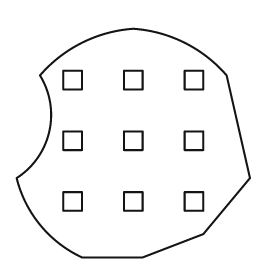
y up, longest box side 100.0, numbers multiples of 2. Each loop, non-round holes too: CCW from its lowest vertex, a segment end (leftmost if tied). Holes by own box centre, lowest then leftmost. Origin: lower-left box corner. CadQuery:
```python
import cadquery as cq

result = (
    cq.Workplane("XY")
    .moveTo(28.0, 0.0)
    .lineTo(54.0, 0.0)
    .lineTo(80.0, 10.0)
    .lineTo(100.0, 34.0)
    .lineTo(90.0, 78.0)
    .threePointArc((72.0, 92.0), (50.0, 98.0))
    .threePointArc((28.0, 92.0), (10.0, 78.0))
    .threePointArc((14.0, 54.0), (0.0, 34.0))
    .threePointArc((10.0, 14.0), (28.0, 0.0))
    .close()
    .moveTo(20.0, 20.0)
    .lineTo(28.0, 20.0)
    .lineTo(28.0, 28.0)
    .lineTo(20.0, 28.0)
    .close()
    .moveTo(46.0, 20.0)
    .lineTo(54.0, 20.0)
    .lineTo(54.0, 28.0)
    .lineTo(46.0, 28.0)
    .close()
    .moveTo(72.0, 20.0)
    .lineTo(80.0, 20.0)
    .lineTo(80.0, 28.0)
    .lineTo(72.0, 28.0)
    .close()
    .moveTo(20.0, 46.0)
    .lineTo(28.0, 46.0)
    .lineTo(28.0, 54.0)
    .lineTo(20.0, 54.0)
    .close()
    .moveTo(46.0, 46.0)
    .lineTo(54.0, 46.0)
    .lineTo(54.0, 54.0)
    .lineTo(46.0, 54.0)
    .close()
    .moveTo(72.0, 46.0)
    .lineTo(80.0, 46.0)
    .lineTo(80.0, 54.0)
    .lineTo(72.0, 54.0)
    .close()
    .moveTo(20.0, 72.0)
    .lineTo(28.0, 72.0)
    .lineTo(28.0, 80.0)
    .lineTo(20.0, 80.0)
    .close()
    .moveTo(46.0, 72.0)
    .lineTo(54.0, 72.0)
    .lineTo(54.0, 80.0)
    .lineTo(46.0, 80.0)
    .close()
    .moveTo(72.0, 72.0)
    .lineTo(80.0, 72.0)
    .lineTo(80.0, 80.0)
    .lineTo(72.0, 80.0)
    .close()
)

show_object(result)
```